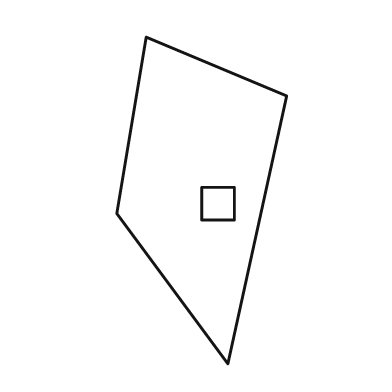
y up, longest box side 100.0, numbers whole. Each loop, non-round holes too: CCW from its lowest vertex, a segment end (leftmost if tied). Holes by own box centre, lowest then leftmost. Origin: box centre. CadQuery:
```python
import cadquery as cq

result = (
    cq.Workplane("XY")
    .moveTo(8.0, -50.0)
    .lineTo(26.0, 32.0)
    .lineTo(-17.0, 50.0)
    .lineTo(-26.0, -4.0)
    .close()
    .moveTo(0.0, -6.0)
    .lineTo(10.0, -6.0)
    .lineTo(10.0, 4.0)
    .lineTo(0.0, 4.0)
    .close()
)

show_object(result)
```